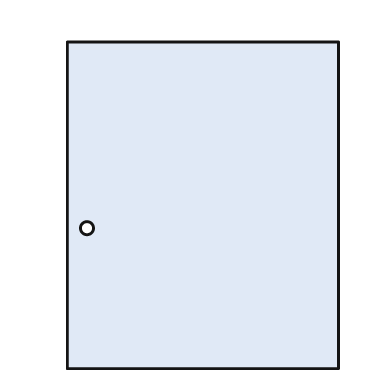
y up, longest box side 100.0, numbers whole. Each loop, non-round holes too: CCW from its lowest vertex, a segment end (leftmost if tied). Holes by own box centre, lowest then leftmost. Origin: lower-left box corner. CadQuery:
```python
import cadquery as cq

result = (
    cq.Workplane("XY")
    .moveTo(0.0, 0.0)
    .lineTo(83.0, 0.0)
    .lineTo(83.0, 100.0)
    .lineTo(0.0, 100.0)
    .close()
    .moveTo(6.0, 43.0)
    .circle(2.0)
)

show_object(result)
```